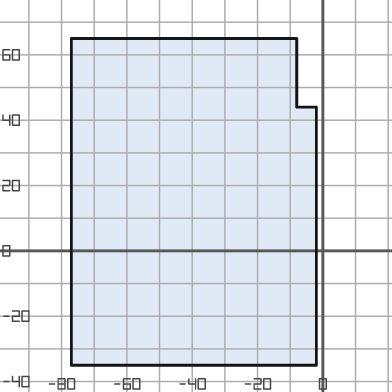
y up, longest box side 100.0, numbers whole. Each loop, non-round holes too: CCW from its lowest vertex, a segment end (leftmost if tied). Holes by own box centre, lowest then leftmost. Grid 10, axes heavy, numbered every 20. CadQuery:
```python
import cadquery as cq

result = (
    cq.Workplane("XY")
    .moveTo(-77.0, -35.0)
    .lineTo(-2.0, -35.0)
    .lineTo(-2.0, 44.0)
    .lineTo(-8.0, 44.0)
    .lineTo(-8.0, 65.0)
    .lineTo(-77.0, 65.0)
    .close()
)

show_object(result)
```